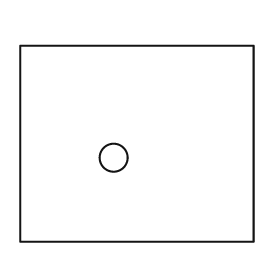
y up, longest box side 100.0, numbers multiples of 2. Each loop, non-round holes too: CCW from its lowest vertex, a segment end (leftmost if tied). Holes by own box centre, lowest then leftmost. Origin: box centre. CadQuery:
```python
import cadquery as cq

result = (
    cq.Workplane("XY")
    .moveTo(-50.0, -42.0)
    .lineTo(50.0, -42.0)
    .lineTo(50.0, 42.0)
    .lineTo(-50.0, 42.0)
    .close()
    .moveTo(-10.0, -6.0)
    .circle(6.0)
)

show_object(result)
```